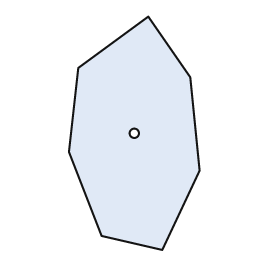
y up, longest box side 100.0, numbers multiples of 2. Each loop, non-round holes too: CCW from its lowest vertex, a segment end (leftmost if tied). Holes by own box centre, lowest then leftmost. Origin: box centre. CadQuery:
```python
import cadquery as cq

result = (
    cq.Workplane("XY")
    .moveTo(12.0, -50.0)
    .lineTo(28.0, -16.0)
    .lineTo(24.0, 24.0)
    .lineTo(6.0, 50.0)
    .lineTo(-24.0, 28.0)
    .lineTo(-28.0, -8.0)
    .lineTo(-14.0, -44.0)
    .close()
    .moveTo(0.0, 0.0)
    .circle(2.0)
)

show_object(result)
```